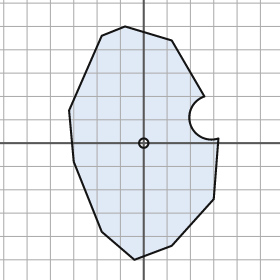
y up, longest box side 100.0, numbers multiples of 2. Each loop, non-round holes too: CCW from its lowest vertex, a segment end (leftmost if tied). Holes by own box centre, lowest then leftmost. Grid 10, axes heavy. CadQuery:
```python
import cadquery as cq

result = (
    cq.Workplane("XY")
    .moveTo(-4.0, -50.0)
    .lineTo(12.0, -44.0)
    .lineTo(30.0, -24.0)
    .lineTo(32.0, 2.0)
    .threePointArc((20.0, 8.0), (26.0, 20.0))
    .lineTo(12.0, 44.0)
    .lineTo(-8.0, 50.0)
    .lineTo(-18.0, 46.0)
    .lineTo(-32.0, 14.0)
    .lineTo(-30.0, -8.0)
    .lineTo(-18.0, -38.0)
    .close()
    .moveTo(0.0, 0.0)
    .circle(2.0)
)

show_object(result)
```